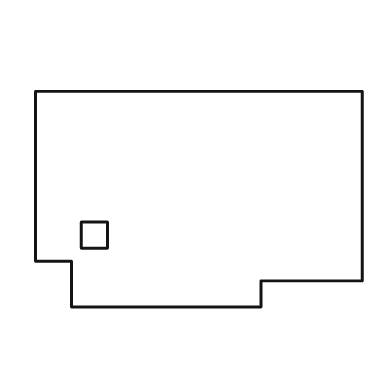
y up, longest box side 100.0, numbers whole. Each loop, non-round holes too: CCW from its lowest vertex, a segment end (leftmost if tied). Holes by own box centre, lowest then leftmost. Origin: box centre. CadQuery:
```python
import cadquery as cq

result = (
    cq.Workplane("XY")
    .moveTo(-39.0, -33.0)
    .lineTo(19.0, -33.0)
    .lineTo(19.0, -25.0)
    .lineTo(50.0, -25.0)
    .lineTo(50.0, 33.0)
    .lineTo(-50.0, 33.0)
    .lineTo(-50.0, -19.0)
    .lineTo(-39.0, -19.0)
    .close()
    .moveTo(-36.0, -15.0)
    .lineTo(-28.0, -15.0)
    .lineTo(-28.0, -7.0)
    .lineTo(-36.0, -7.0)
    .close()
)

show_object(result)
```